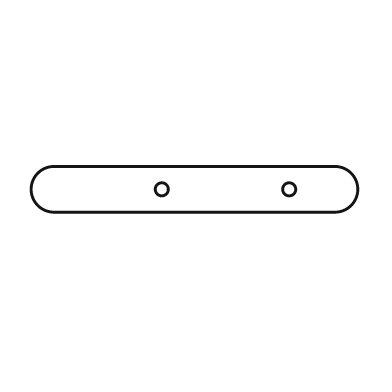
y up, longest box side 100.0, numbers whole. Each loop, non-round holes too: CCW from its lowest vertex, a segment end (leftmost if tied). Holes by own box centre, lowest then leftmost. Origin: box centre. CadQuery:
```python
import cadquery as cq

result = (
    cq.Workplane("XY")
    .moveTo(-43.0, -7.0)
    .lineTo(43.0, -7.0)
    .threePointArc((50.0, 0.0), (43.0, 7.0))
    .lineTo(-43.0, 7.0)
    .threePointArc((-50.0, 0.0), (-43.0, -7.0))
    .close()
    .moveTo(-10.0, 0.0)
    .circle(2.0)
    .moveTo(29.0, 0.0)
    .circle(2.0)
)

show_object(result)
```